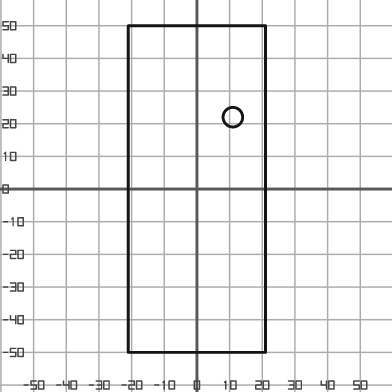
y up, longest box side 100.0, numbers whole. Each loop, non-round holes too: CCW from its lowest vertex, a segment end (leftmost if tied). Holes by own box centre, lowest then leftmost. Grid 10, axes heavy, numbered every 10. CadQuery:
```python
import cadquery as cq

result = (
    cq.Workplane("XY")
    .moveTo(-21.0, -50.0)
    .lineTo(21.0, -50.0)
    .lineTo(21.0, 50.0)
    .lineTo(-21.0, 50.0)
    .close()
    .moveTo(11.0, 22.0)
    .circle(3.0)
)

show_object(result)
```